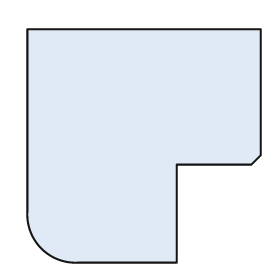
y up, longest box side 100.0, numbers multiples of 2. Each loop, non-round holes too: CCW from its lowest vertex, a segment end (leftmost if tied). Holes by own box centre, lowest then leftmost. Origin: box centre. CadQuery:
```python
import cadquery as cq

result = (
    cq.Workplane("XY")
    .moveTo(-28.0, -50.0)
    .lineTo(14.0, -50.0)
    .lineTo(14.0, -8.0)
    .lineTo(46.0, -8.0)
    .lineTo(50.0, -4.0)
    .lineTo(50.0, 50.0)
    .lineTo(-50.0, 50.0)
    .lineTo(-50.0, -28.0)
    .threePointArc((-44.0, -44.0), (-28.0, -50.0))
    .close()
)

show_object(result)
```